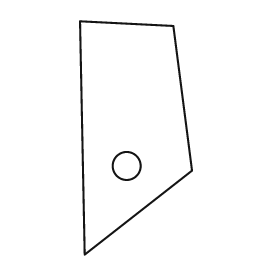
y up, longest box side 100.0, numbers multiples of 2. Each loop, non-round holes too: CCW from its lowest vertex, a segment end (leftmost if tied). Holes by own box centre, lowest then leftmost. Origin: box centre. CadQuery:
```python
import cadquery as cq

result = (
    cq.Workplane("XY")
    .moveTo(-22.0, -50.0)
    .lineTo(24.0, -14.0)
    .lineTo(16.0, 48.0)
    .lineTo(-24.0, 50.0)
    .close()
    .moveTo(-4.0, -12.0)
    .circle(6.0)
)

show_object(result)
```